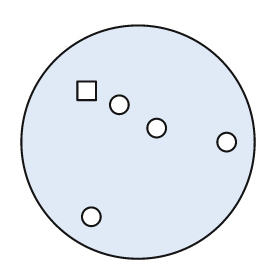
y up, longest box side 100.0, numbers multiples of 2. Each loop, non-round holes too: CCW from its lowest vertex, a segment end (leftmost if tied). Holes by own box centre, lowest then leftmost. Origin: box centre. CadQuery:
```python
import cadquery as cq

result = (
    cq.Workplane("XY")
    .moveTo(0.0, 0.0)
    .circle(50.0)
    .moveTo(-20.0, -32.0)
    .circle(4.0)
    .moveTo(38.0, 0.0)
    .circle(4.0)
    .moveTo(8.0, 6.0)
    .circle(4.0)
    .moveTo(-8.0, 16.0)
    .circle(4.0)
    .moveTo(-26.0, 18.0)
    .lineTo(-18.0, 18.0)
    .lineTo(-18.0, 26.0)
    .lineTo(-26.0, 26.0)
    .close()
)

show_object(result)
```